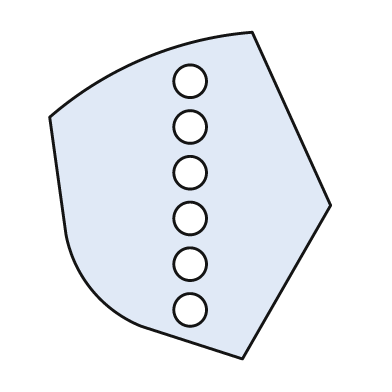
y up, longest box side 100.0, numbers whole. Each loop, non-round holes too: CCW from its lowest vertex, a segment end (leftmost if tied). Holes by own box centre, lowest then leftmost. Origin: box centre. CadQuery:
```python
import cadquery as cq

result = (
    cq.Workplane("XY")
    .moveTo(16.0, -50.0)
    .lineTo(43.0, -3.0)
    .lineTo(19.0, 50.0)
    .threePointArc((-14.0, 42.0), (-43.0, 24.0))
    .lineTo(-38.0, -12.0)
    .threePointArc((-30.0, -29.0), (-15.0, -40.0))
    .close()
    .moveTo(0.0, -35.0)
    .circle(5.0)
    .moveTo(0.0, -21.0)
    .circle(5.0)
    .moveTo(0.0, -7.0)
    .circle(5.0)
    .moveTo(0.0, 7.0)
    .circle(5.0)
    .moveTo(0.0, 21.0)
    .circle(5.0)
    .moveTo(0.0, 35.0)
    .circle(5.0)
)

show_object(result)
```